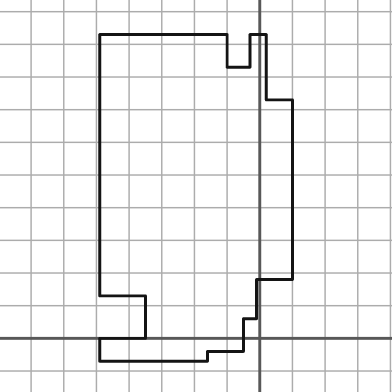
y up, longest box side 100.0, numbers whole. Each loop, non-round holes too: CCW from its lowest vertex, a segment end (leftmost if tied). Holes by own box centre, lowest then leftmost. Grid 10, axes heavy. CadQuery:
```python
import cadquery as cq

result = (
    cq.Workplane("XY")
    .moveTo(-49.0, -7.0)
    .lineTo(-16.0, -7.0)
    .lineTo(-16.0, -4.0)
    .lineTo(-5.0, -4.0)
    .lineTo(-5.0, 6.0)
    .lineTo(-1.0, 6.0)
    .lineTo(-1.0, 18.0)
    .lineTo(10.0, 18.0)
    .lineTo(10.0, 73.0)
    .lineTo(2.0, 73.0)
    .lineTo(2.0, 93.0)
    .lineTo(-3.0, 93.0)
    .lineTo(-3.0, 83.0)
    .lineTo(-10.0, 83.0)
    .lineTo(-10.0, 93.0)
    .lineTo(-49.0, 93.0)
    .lineTo(-49.0, 13.0)
    .lineTo(-35.0, 13.0)
    .lineTo(-35.0, 0.0)
    .lineTo(-49.0, 0.0)
    .close()
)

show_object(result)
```